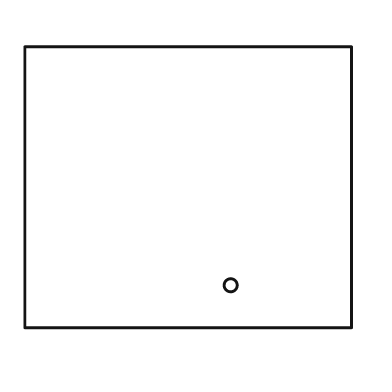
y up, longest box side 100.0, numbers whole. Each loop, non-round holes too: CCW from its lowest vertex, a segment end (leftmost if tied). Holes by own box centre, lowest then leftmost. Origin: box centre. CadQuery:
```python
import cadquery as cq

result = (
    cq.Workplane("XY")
    .moveTo(-50.0, -43.0)
    .lineTo(50.0, -43.0)
    .lineTo(50.0, 43.0)
    .lineTo(-50.0, 43.0)
    .close()
    .moveTo(13.0, -30.0)
    .circle(2.0)
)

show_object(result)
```